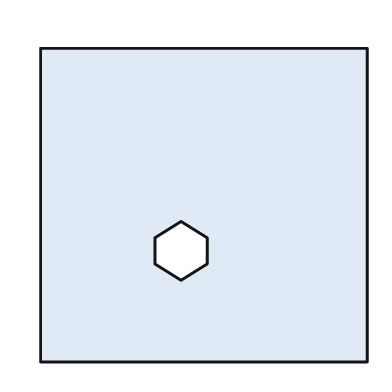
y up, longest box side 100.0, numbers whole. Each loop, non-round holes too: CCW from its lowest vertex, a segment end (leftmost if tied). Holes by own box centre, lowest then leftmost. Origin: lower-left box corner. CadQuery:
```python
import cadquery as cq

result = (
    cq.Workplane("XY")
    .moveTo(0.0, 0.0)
    .lineTo(100.0, 0.0)
    .lineTo(100.0, 96.0)
    .lineTo(0.0, 96.0)
    .close()
    .moveTo(43.0, 25.0)
    .lineTo(51.0, 30.0)
    .lineTo(51.0, 38.0)
    .lineTo(43.0, 43.0)
    .lineTo(35.0, 38.0)
    .lineTo(35.0, 30.0)
    .close()
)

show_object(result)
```